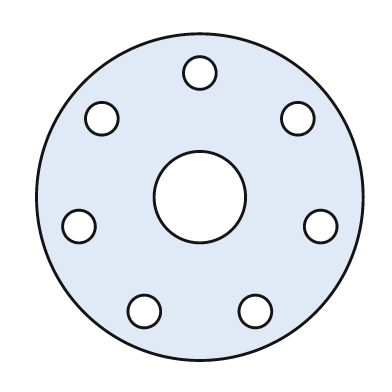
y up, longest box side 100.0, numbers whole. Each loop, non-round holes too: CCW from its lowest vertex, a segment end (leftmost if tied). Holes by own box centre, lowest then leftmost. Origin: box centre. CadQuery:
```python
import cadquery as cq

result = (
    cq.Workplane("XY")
    .moveTo(0.0, 0.0)
    .circle(50.0)
    .moveTo(-17.0, -35.0)
    .circle(5.0)
    .moveTo(17.0, -35.0)
    .circle(5.0)
    .moveTo(-37.0, -9.0)
    .circle(5.0)
    .moveTo(37.0, -9.0)
    .circle(5.0)
    .moveTo(0.0, 0.0)
    .circle(14.0)
    .moveTo(-30.0, 24.0)
    .circle(5.0)
    .moveTo(30.0, 24.0)
    .circle(5.0)
    .moveTo(0.0, 38.0)
    .circle(5.0)
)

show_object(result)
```